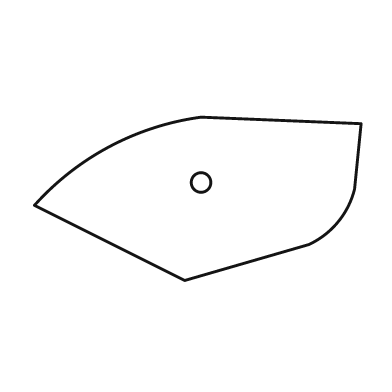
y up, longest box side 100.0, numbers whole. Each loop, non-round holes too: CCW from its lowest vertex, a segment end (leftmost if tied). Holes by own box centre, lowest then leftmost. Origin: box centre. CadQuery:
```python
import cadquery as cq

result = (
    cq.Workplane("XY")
    .moveTo(-4.0, -25.0)
    .lineTo(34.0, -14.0)
    .threePointArc((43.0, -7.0), (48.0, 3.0))
    .lineTo(50.0, 23.0)
    .lineTo(1.0, 25.0)
    .threePointArc((-27.0, 16.0), (-50.0, -2.0))
    .close()
    .moveTo(1.0, 5.0)
    .circle(3.0)
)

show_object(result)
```